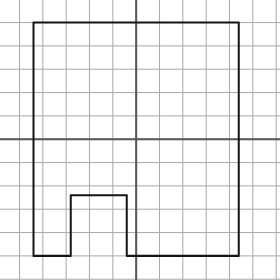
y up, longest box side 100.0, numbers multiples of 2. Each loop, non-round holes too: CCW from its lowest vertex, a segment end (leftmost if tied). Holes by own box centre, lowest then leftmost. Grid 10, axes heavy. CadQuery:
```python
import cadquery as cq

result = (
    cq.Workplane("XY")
    .moveTo(-44.0, -50.0)
    .lineTo(-28.0, -50.0)
    .lineTo(-28.0, -24.0)
    .lineTo(-4.0, -24.0)
    .lineTo(-4.0, -50.0)
    .lineTo(44.0, -50.0)
    .lineTo(44.0, 50.0)
    .lineTo(-44.0, 50.0)
    .close()
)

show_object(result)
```